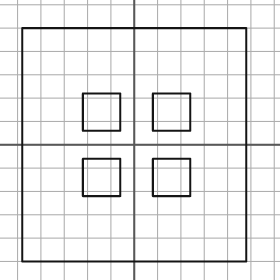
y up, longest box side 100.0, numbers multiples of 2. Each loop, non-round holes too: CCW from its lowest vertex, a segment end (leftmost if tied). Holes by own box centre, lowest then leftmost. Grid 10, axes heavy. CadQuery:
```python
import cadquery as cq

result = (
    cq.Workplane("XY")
    .moveTo(-48.0, -50.0)
    .lineTo(48.0, -50.0)
    .lineTo(48.0, 50.0)
    .lineTo(-48.0, 50.0)
    .close()
    .moveTo(-22.0, -22.0)
    .lineTo(-6.0, -22.0)
    .lineTo(-6.0, -6.0)
    .lineTo(-22.0, -6.0)
    .close()
    .moveTo(8.0, -22.0)
    .lineTo(24.0, -22.0)
    .lineTo(24.0, -6.0)
    .lineTo(8.0, -6.0)
    .close()
    .moveTo(-22.0, 6.0)
    .lineTo(-6.0, 6.0)
    .lineTo(-6.0, 22.0)
    .lineTo(-22.0, 22.0)
    .close()
    .moveTo(8.0, 6.0)
    .lineTo(24.0, 6.0)
    .lineTo(24.0, 22.0)
    .lineTo(8.0, 22.0)
    .close()
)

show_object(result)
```